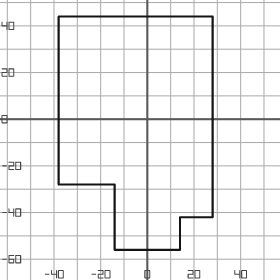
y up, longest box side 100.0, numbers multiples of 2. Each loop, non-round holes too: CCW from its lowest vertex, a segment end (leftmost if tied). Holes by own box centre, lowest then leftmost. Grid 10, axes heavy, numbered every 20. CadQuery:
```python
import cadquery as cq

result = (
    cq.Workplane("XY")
    .moveTo(-14.0, -56.0)
    .lineTo(14.0, -56.0)
    .lineTo(14.0, -42.0)
    .lineTo(28.0, -42.0)
    .lineTo(28.0, 44.0)
    .lineTo(-38.0, 44.0)
    .lineTo(-38.0, -28.0)
    .lineTo(-14.0, -28.0)
    .close()
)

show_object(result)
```